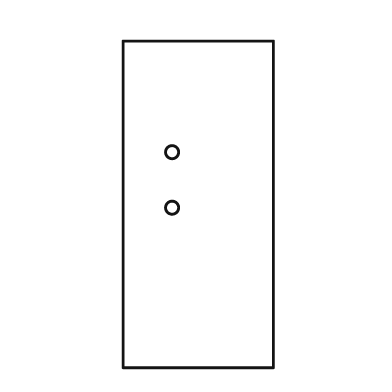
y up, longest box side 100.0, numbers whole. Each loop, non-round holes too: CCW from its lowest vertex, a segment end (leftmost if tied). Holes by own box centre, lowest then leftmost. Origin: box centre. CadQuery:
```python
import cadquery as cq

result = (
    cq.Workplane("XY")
    .moveTo(-23.0, -50.0)
    .lineTo(23.0, -50.0)
    .lineTo(23.0, 50.0)
    .lineTo(-23.0, 50.0)
    .close()
    .moveTo(-8.0, -1.0)
    .circle(2.0)
    .moveTo(-8.0, 16.0)
    .circle(2.0)
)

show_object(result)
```